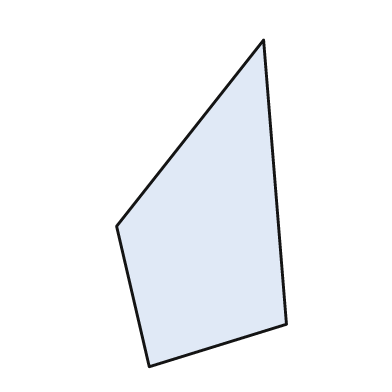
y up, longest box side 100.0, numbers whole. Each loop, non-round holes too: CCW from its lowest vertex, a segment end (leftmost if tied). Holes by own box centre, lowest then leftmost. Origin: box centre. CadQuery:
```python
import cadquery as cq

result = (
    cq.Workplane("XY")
    .moveTo(-16.0, -50.0)
    .lineTo(26.0, -37.0)
    .lineTo(19.0, 50.0)
    .lineTo(-26.0, -7.0)
    .close()
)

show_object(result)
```